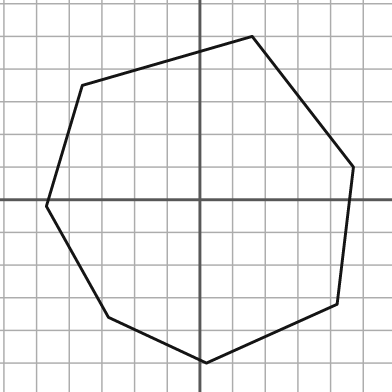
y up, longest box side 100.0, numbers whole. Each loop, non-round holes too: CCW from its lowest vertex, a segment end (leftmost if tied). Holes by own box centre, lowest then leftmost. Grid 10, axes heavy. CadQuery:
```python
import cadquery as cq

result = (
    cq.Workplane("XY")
    .moveTo(2.0, -50.0)
    .lineTo(42.0, -32.0)
    .lineTo(47.0, 10.0)
    .lineTo(16.0, 50.0)
    .lineTo(-36.0, 35.0)
    .lineTo(-47.0, -2.0)
    .lineTo(-28.0, -36.0)
    .close()
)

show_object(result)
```